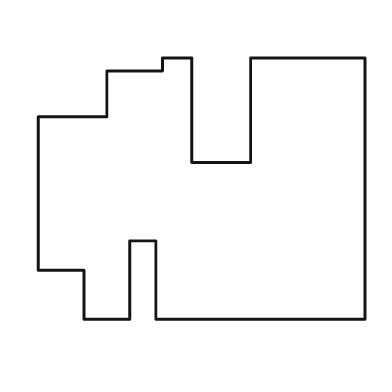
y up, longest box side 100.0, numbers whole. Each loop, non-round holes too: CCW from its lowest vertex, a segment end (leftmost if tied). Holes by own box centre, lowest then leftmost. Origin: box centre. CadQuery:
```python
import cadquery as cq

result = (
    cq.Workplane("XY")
    .moveTo(-36.0, -40.0)
    .lineTo(-22.0, -40.0)
    .lineTo(-22.0, -16.0)
    .lineTo(-14.0, -16.0)
    .lineTo(-14.0, -40.0)
    .lineTo(50.0, -40.0)
    .lineTo(50.0, 40.0)
    .lineTo(15.0, 40.0)
    .lineTo(15.0, 8.0)
    .lineTo(-3.0, 8.0)
    .lineTo(-3.0, 40.0)
    .lineTo(-12.0, 40.0)
    .lineTo(-12.0, 36.0)
    .lineTo(-29.0, 36.0)
    .lineTo(-29.0, 22.0)
    .lineTo(-50.0, 22.0)
    .lineTo(-50.0, -25.0)
    .lineTo(-36.0, -25.0)
    .close()
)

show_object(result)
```